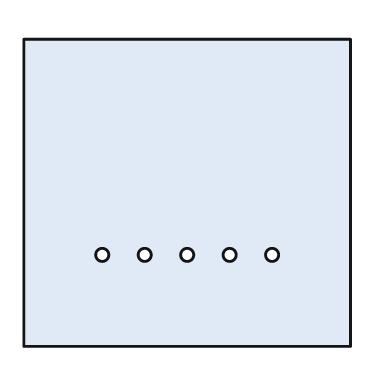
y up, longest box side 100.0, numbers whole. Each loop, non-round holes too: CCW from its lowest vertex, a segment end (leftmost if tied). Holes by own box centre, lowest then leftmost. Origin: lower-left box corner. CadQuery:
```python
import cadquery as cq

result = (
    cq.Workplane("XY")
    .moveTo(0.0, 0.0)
    .lineTo(100.0, 0.0)
    .lineTo(100.0, 94.0)
    .lineTo(0.0, 94.0)
    .close()
    .moveTo(24.0, 28.0)
    .circle(2.0)
    .moveTo(37.0, 28.0)
    .circle(2.0)
    .moveTo(50.0, 28.0)
    .circle(2.0)
    .moveTo(63.0, 28.0)
    .circle(2.0)
    .moveTo(76.0, 28.0)
    .circle(2.0)
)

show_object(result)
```